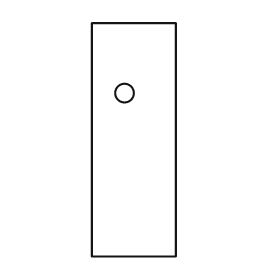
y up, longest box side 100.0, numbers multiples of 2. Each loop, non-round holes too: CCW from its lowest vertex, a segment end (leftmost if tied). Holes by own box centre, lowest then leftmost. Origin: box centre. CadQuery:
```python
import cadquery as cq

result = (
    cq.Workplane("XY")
    .moveTo(-18.0, -50.0)
    .lineTo(18.0, -50.0)
    .lineTo(18.0, 50.0)
    .lineTo(-18.0, 50.0)
    .close()
    .moveTo(-4.0, 20.0)
    .circle(4.0)
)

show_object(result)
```